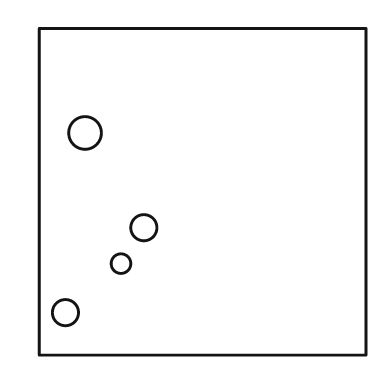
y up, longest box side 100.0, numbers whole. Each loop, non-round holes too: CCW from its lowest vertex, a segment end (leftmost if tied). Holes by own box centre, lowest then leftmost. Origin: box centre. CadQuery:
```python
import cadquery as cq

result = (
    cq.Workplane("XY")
    .moveTo(-50.0, -50.0)
    .lineTo(50.0, -50.0)
    .lineTo(50.0, 50.0)
    .lineTo(-50.0, 50.0)
    .close()
    .moveTo(-42.0, -37.0)
    .circle(4.0)
    .moveTo(-25.0, -22.0)
    .circle(3.0)
    .moveTo(-18.0, -11.0)
    .circle(4.0)
    .moveTo(-36.0, 18.0)
    .circle(5.0)
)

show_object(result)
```